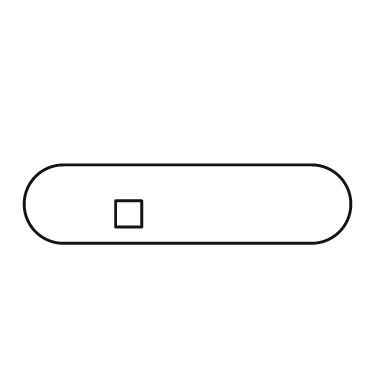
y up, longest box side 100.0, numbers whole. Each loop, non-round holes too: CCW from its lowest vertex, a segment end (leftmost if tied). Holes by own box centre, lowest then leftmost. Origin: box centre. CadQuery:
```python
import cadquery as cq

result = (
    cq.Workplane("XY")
    .moveTo(-38.0, -12.0)
    .lineTo(38.0, -12.0)
    .threePointArc((50.0, 0.0), (38.0, 12.0))
    .lineTo(-38.0, 12.0)
    .threePointArc((-50.0, 0.0), (-38.0, -12.0))
    .close()
    .moveTo(-22.0, -7.0)
    .lineTo(-14.0, -7.0)
    .lineTo(-14.0, 1.0)
    .lineTo(-22.0, 1.0)
    .close()
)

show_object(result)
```